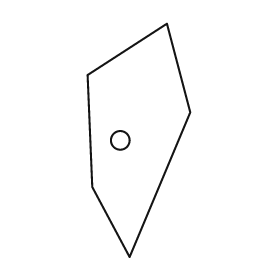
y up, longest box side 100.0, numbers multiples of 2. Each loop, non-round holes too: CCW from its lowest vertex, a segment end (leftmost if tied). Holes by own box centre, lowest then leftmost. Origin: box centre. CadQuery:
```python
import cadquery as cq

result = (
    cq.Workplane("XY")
    .moveTo(-4.0, -50.0)
    .lineTo(22.0, 12.0)
    .lineTo(12.0, 50.0)
    .lineTo(-22.0, 28.0)
    .lineTo(-20.0, -20.0)
    .close()
    .moveTo(-8.0, 0.0)
    .circle(4.0)
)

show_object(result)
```